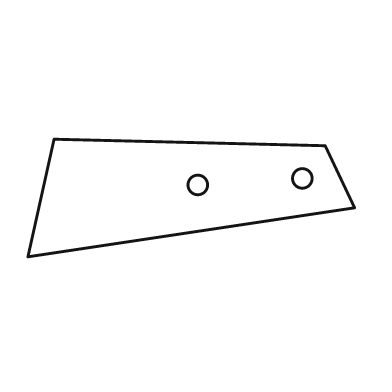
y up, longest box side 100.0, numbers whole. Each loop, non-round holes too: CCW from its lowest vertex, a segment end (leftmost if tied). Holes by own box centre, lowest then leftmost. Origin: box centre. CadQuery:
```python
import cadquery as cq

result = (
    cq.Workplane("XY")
    .moveTo(-50.0, -18.0)
    .lineTo(50.0, -3.0)
    .lineTo(41.0, 16.0)
    .lineTo(-42.0, 18.0)
    .close()
    .moveTo(2.0, 4.0)
    .circle(3.0)
    .moveTo(34.0, 6.0)
    .circle(3.0)
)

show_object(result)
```